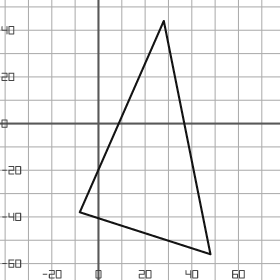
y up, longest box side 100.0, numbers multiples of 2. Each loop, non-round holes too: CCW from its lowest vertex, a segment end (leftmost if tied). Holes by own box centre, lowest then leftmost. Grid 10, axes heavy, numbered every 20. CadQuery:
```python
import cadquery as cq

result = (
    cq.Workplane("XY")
    .moveTo(48.0, -56.0)
    .lineTo(28.0, 44.0)
    .lineTo(-8.0, -38.0)
    .close()
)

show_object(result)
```